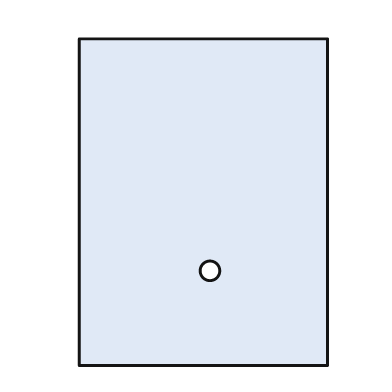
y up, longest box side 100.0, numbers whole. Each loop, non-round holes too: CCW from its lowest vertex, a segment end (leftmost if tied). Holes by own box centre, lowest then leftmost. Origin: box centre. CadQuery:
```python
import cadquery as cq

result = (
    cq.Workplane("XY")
    .moveTo(-38.0, -50.0)
    .lineTo(38.0, -50.0)
    .lineTo(38.0, 50.0)
    .lineTo(-38.0, 50.0)
    .close()
    .moveTo(2.0, -21.0)
    .circle(3.0)
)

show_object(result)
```